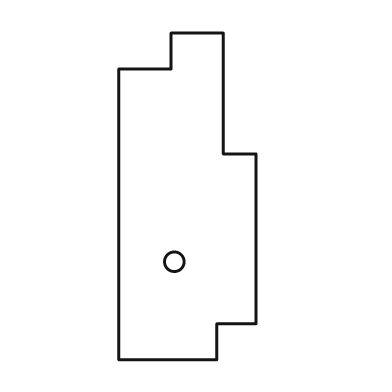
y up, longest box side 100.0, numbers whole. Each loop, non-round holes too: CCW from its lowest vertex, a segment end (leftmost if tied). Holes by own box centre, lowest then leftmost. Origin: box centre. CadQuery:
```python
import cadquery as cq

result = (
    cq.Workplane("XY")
    .moveTo(-21.0, -50.0)
    .lineTo(9.0, -50.0)
    .lineTo(9.0, -39.0)
    .lineTo(21.0, -39.0)
    .lineTo(21.0, 13.0)
    .lineTo(11.0, 13.0)
    .lineTo(11.0, 50.0)
    .lineTo(-5.0, 50.0)
    .lineTo(-5.0, 39.0)
    .lineTo(-21.0, 39.0)
    .close()
    .moveTo(-4.0, -20.0)
    .circle(3.0)
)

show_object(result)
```